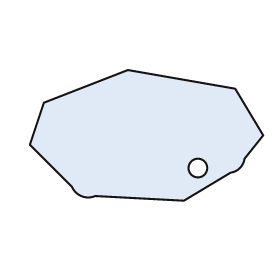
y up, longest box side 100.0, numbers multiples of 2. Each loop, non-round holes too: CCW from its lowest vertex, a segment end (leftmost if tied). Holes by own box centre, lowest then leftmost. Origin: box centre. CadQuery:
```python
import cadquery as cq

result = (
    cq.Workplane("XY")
    .moveTo(16.0, -28.0)
    .lineTo(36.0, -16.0)
    .threePointArc((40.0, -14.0), (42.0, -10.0))
    .lineTo(50.0, 0.0)
    .lineTo(38.0, 20.0)
    .lineTo(-8.0, 28.0)
    .lineTo(-44.0, 14.0)
    .lineTo(-50.0, -4.0)
    .lineTo(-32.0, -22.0)
    .threePointArc((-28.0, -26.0), (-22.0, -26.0))
    .close()
    .moveTo(22.0, -14.0)
    .circle(4.0)
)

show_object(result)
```